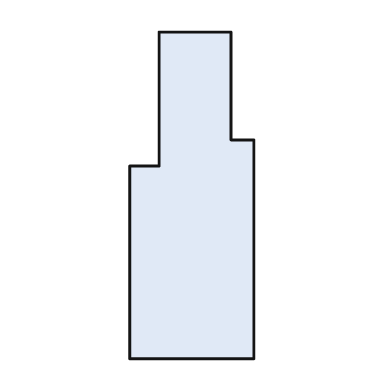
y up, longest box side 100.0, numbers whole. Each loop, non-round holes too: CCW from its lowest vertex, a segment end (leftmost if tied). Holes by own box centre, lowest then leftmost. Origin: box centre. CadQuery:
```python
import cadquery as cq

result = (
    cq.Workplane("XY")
    .moveTo(-19.0, -50.0)
    .lineTo(19.0, -50.0)
    .lineTo(19.0, 17.0)
    .lineTo(12.0, 17.0)
    .lineTo(12.0, 50.0)
    .lineTo(-10.0, 50.0)
    .lineTo(-10.0, 9.0)
    .lineTo(-19.0, 9.0)
    .close()
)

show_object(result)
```